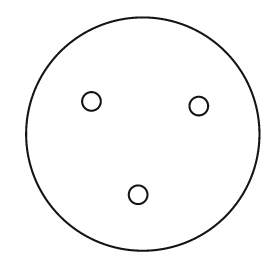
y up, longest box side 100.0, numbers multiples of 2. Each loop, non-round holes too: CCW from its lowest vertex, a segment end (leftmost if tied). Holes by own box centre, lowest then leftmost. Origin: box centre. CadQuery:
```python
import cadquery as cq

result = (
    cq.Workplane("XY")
    .moveTo(0.0, 0.0)
    .circle(50.0)
    .moveTo(-2.0, -26.0)
    .circle(4.0)
    .moveTo(24.0, 12.0)
    .circle(4.0)
    .moveTo(-22.0, 14.0)
    .circle(4.0)
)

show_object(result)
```